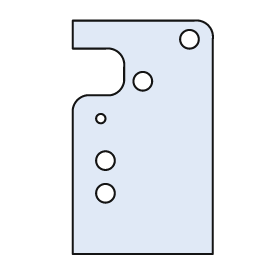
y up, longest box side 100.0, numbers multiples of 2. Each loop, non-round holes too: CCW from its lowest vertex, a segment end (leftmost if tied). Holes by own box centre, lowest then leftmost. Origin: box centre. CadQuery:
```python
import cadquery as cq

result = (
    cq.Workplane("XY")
    .moveTo(-30.0, -50.0)
    .lineTo(30.0, -50.0)
    .lineTo(30.0, 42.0)
    .threePointArc((28.0, 48.0), (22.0, 50.0))
    .lineTo(-30.0, 50.0)
    .lineTo(-30.0, 38.0)
    .lineTo(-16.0, 38.0)
    .threePointArc((-10.0, 36.0), (-8.0, 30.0))
    .lineTo(-8.0, 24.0)
    .threePointArc((-10.0, 20.0), (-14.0, 18.0))
    .lineTo(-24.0, 18.0)
    .threePointArc((-28.0, 16.0), (-30.0, 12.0))
    .close()
    .moveTo(-16.0, -24.0)
    .circle(4.0)
    .moveTo(-16.0, -10.0)
    .circle(4.0)
    .moveTo(-18.0, 8.0)
    .circle(2.0)
    .moveTo(0.0, 24.0)
    .circle(4.0)
    .moveTo(20.0, 42.0)
    .circle(4.0)
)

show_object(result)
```